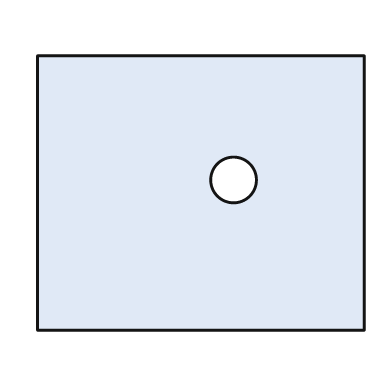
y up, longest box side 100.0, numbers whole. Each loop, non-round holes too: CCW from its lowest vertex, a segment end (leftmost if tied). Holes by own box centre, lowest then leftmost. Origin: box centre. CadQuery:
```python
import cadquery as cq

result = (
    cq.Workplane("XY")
    .moveTo(-50.0, -42.0)
    .lineTo(50.0, -42.0)
    .lineTo(50.0, 42.0)
    .lineTo(-50.0, 42.0)
    .close()
    .moveTo(10.0, 4.0)
    .circle(7.0)
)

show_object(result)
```